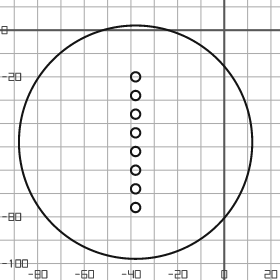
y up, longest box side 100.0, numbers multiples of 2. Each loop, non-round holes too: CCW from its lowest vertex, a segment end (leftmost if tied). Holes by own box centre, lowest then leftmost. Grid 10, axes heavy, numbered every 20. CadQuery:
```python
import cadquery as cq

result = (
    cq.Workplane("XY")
    .moveTo(-38.0, -48.0)
    .circle(50.0)
    .moveTo(-38.0, -76.0)
    .circle(2.0)
    .moveTo(-38.0, -68.0)
    .circle(2.0)
    .moveTo(-38.0, -60.0)
    .circle(2.0)
    .moveTo(-38.0, -52.0)
    .circle(2.0)
    .moveTo(-38.0, -44.0)
    .circle(2.0)
    .moveTo(-38.0, -36.0)
    .circle(2.0)
    .moveTo(-38.0, -28.0)
    .circle(2.0)
    .moveTo(-38.0, -20.0)
    .circle(2.0)
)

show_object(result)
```